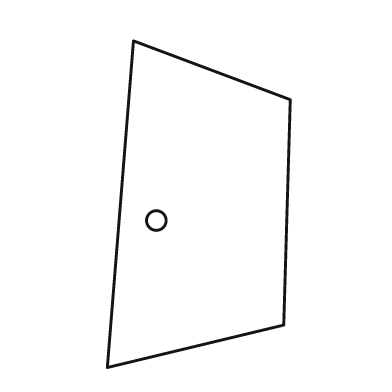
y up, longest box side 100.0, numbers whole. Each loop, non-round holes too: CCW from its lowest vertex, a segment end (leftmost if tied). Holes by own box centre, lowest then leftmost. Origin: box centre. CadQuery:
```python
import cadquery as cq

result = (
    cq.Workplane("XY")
    .moveTo(-28.0, -50.0)
    .lineTo(26.0, -37.0)
    .lineTo(28.0, 32.0)
    .lineTo(-20.0, 50.0)
    .close()
    .moveTo(-13.0, -5.0)
    .circle(3.0)
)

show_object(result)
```